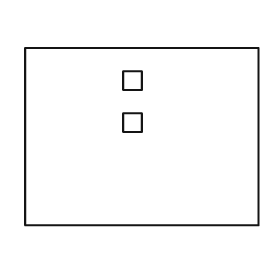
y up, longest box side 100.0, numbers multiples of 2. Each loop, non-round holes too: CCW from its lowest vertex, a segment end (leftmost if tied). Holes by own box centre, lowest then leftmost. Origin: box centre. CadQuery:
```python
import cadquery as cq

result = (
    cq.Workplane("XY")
    .moveTo(-50.0, -38.0)
    .lineTo(50.0, -38.0)
    .lineTo(50.0, 38.0)
    .lineTo(-50.0, 38.0)
    .close()
    .moveTo(-8.0, 2.0)
    .lineTo(0.0, 2.0)
    .lineTo(0.0, 10.0)
    .lineTo(-8.0, 10.0)
    .close()
    .moveTo(-8.0, 20.0)
    .lineTo(0.0, 20.0)
    .lineTo(0.0, 28.0)
    .lineTo(-8.0, 28.0)
    .close()
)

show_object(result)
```